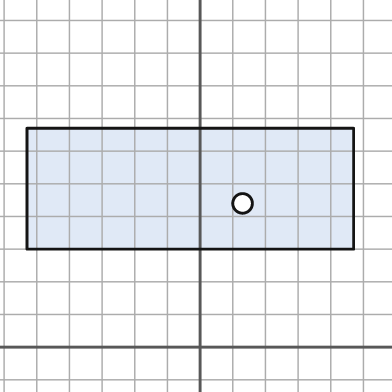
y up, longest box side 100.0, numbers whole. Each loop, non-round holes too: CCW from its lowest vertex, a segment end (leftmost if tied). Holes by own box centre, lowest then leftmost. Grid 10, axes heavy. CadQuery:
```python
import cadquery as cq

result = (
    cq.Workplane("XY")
    .moveTo(-53.0, 30.0)
    .lineTo(47.0, 30.0)
    .lineTo(47.0, 67.0)
    .lineTo(-53.0, 67.0)
    .close()
    .moveTo(13.0, 44.0)
    .circle(3.0)
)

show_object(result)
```